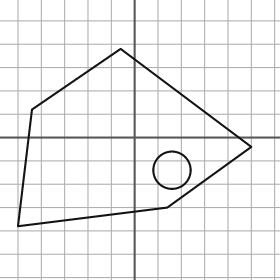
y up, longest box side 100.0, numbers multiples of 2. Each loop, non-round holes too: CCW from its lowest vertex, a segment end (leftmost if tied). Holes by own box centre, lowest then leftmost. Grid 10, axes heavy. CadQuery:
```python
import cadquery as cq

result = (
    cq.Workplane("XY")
    .moveTo(-50.0, -38.0)
    .lineTo(14.0, -30.0)
    .lineTo(50.0, -4.0)
    .lineTo(-6.0, 38.0)
    .lineTo(-44.0, 12.0)
    .close()
    .moveTo(16.0, -14.0)
    .circle(8.0)
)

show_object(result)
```